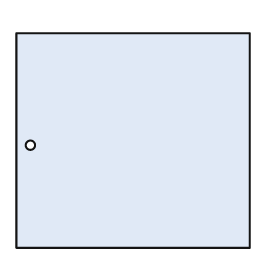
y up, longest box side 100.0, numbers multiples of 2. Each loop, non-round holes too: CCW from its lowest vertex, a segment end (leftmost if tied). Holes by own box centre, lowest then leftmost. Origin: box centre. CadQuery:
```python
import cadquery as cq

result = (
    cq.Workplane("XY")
    .moveTo(-50.0, -46.0)
    .lineTo(50.0, -46.0)
    .lineTo(50.0, 46.0)
    .lineTo(-50.0, 46.0)
    .close()
    .moveTo(-44.0, -2.0)
    .circle(2.0)
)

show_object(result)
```